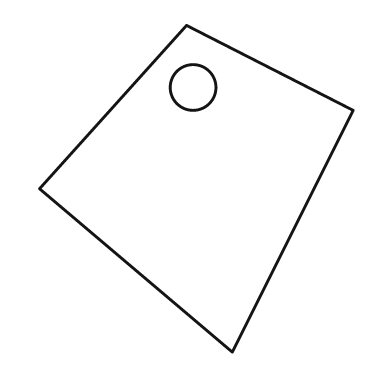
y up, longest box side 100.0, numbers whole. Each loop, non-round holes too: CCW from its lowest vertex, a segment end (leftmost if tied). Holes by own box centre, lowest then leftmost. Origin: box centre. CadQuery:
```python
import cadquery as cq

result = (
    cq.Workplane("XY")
    .moveTo(11.0, -50.0)
    .lineTo(48.0, 24.0)
    .lineTo(-3.0, 50.0)
    .lineTo(-48.0, 0.0)
    .close()
    .moveTo(-1.0, 31.0)
    .circle(7.0)
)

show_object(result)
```